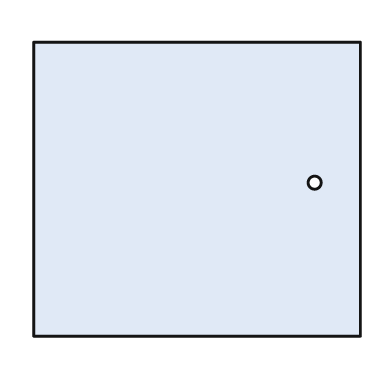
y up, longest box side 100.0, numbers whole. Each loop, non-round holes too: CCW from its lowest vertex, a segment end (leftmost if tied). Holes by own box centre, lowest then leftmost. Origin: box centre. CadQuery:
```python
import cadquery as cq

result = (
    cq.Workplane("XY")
    .moveTo(-50.0, -45.0)
    .lineTo(50.0, -45.0)
    .lineTo(50.0, 45.0)
    .lineTo(-50.0, 45.0)
    .close()
    .moveTo(36.0, 2.0)
    .circle(2.0)
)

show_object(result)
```